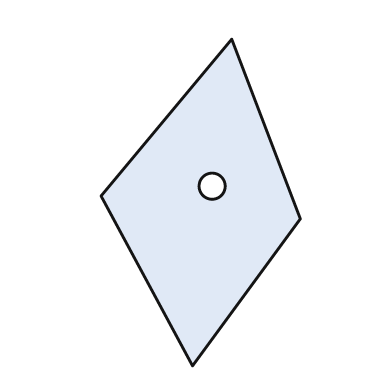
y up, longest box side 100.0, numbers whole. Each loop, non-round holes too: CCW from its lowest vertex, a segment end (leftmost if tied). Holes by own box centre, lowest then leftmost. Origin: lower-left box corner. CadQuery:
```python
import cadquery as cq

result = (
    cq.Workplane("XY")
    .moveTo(28.0, 0.0)
    .lineTo(61.0, 45.0)
    .lineTo(40.0, 100.0)
    .lineTo(0.0, 52.0)
    .close()
    .moveTo(34.0, 55.0)
    .circle(4.0)
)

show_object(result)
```